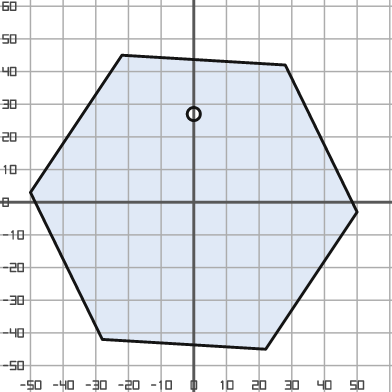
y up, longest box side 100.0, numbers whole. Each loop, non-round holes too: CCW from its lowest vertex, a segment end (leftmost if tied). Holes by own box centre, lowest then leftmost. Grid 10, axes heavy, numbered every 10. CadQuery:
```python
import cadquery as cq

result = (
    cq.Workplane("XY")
    .moveTo(22.0, -45.0)
    .lineTo(50.0, -3.0)
    .lineTo(28.0, 42.0)
    .lineTo(-22.0, 45.0)
    .lineTo(-50.0, 3.0)
    .lineTo(-28.0, -42.0)
    .close()
    .moveTo(0.0, 27.0)
    .circle(2.0)
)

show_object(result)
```